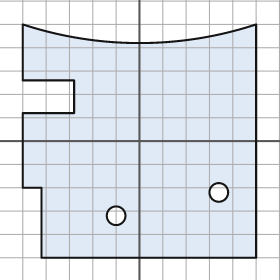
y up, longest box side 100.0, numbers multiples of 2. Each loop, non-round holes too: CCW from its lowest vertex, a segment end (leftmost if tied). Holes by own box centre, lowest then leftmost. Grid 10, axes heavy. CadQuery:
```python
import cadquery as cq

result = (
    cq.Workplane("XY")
    .moveTo(-42.0, -50.0)
    .lineTo(50.0, -50.0)
    .lineTo(50.0, 50.0)
    .threePointArc((0.0, 42.0), (-50.0, 50.0))
    .lineTo(-50.0, 26.0)
    .lineTo(-28.0, 26.0)
    .lineTo(-28.0, 12.0)
    .lineTo(-50.0, 12.0)
    .lineTo(-50.0, -20.0)
    .lineTo(-42.0, -20.0)
    .close()
    .moveTo(-10.0, -32.0)
    .circle(4.0)
    .moveTo(34.0, -22.0)
    .circle(4.0)
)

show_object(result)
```